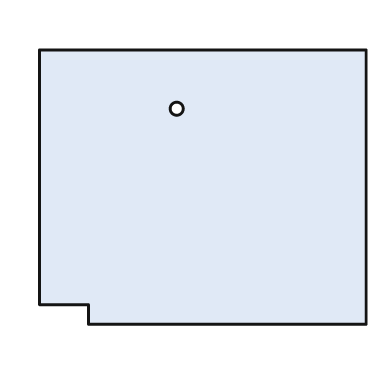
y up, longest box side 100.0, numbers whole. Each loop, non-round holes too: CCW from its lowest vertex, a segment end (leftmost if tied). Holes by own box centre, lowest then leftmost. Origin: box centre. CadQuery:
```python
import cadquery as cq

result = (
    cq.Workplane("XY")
    .moveTo(-35.0, -42.0)
    .lineTo(50.0, -42.0)
    .lineTo(50.0, 42.0)
    .lineTo(-50.0, 42.0)
    .lineTo(-50.0, -36.0)
    .lineTo(-35.0, -36.0)
    .close()
    .moveTo(-8.0, 24.0)
    .circle(2.0)
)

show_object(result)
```